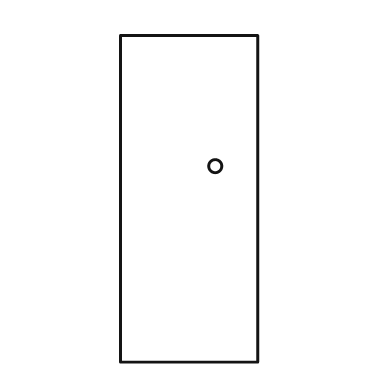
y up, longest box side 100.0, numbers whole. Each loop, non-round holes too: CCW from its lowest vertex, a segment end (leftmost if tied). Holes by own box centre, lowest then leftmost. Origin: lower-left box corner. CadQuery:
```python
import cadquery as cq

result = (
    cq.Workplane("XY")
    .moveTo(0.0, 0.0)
    .lineTo(42.0, 0.0)
    .lineTo(42.0, 100.0)
    .lineTo(0.0, 100.0)
    .close()
    .moveTo(29.0, 60.0)
    .circle(2.0)
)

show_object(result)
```